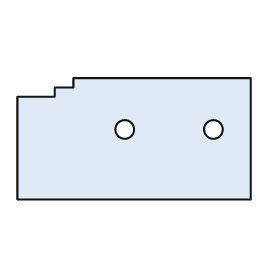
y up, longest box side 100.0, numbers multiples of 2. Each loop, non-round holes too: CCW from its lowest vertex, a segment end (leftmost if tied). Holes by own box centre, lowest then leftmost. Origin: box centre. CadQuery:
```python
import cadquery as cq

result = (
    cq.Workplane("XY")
    .moveTo(-50.0, -26.0)
    .lineTo(50.0, -26.0)
    .lineTo(50.0, 26.0)
    .lineTo(-26.0, 26.0)
    .lineTo(-26.0, 22.0)
    .lineTo(-34.0, 22.0)
    .lineTo(-34.0, 18.0)
    .lineTo(-50.0, 18.0)
    .close()
    .moveTo(-4.0, 4.0)
    .circle(4.0)
    .moveTo(34.0, 4.0)
    .circle(4.0)
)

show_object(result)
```